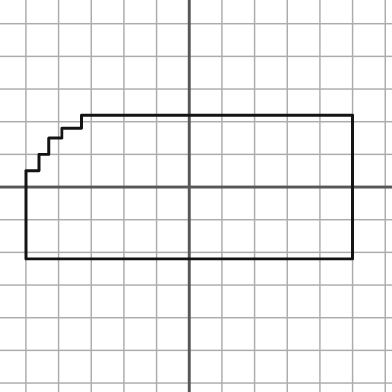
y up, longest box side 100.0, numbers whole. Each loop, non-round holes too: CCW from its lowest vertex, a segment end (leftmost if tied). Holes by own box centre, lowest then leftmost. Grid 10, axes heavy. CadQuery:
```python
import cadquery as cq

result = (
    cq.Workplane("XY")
    .moveTo(-50.0, -22.0)
    .lineTo(50.0, -22.0)
    .lineTo(50.0, 22.0)
    .lineTo(-33.0, 22.0)
    .lineTo(-33.0, 18.0)
    .lineTo(-39.0, 18.0)
    .lineTo(-39.0, 15.0)
    .lineTo(-43.0, 15.0)
    .lineTo(-43.0, 10.0)
    .lineTo(-46.0, 10.0)
    .lineTo(-46.0, 5.0)
    .lineTo(-50.0, 5.0)
    .close()
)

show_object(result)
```